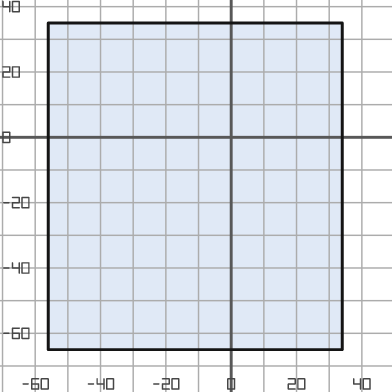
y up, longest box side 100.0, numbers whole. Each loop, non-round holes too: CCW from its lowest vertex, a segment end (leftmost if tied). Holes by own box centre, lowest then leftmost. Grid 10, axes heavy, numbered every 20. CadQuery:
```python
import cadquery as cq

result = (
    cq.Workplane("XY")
    .moveTo(-56.0, -65.0)
    .lineTo(34.0, -65.0)
    .lineTo(34.0, 35.0)
    .lineTo(-56.0, 35.0)
    .close()
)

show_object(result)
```